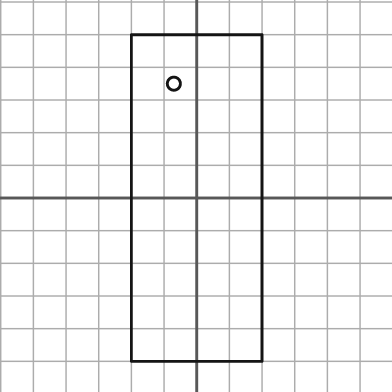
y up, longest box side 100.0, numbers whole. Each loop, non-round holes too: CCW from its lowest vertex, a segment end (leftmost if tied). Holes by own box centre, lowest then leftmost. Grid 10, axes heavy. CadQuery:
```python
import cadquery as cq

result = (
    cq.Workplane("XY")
    .moveTo(-20.0, -50.0)
    .lineTo(20.0, -50.0)
    .lineTo(20.0, 50.0)
    .lineTo(-20.0, 50.0)
    .close()
    .moveTo(-7.0, 35.0)
    .circle(2.0)
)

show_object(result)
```